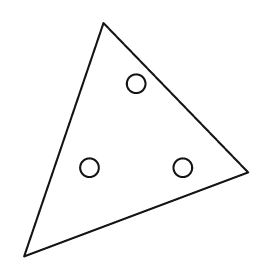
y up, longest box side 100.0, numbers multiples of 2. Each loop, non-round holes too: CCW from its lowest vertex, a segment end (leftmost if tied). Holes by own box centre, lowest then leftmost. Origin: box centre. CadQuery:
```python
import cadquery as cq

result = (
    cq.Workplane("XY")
    .moveTo(-48.0, -50.0)
    .lineTo(48.0, -14.0)
    .lineTo(-14.0, 50.0)
    .close()
    .moveTo(-20.0, -12.0)
    .circle(4.0)
    .moveTo(20.0, -12.0)
    .circle(4.0)
    .moveTo(0.0, 24.0)
    .circle(4.0)
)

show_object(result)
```